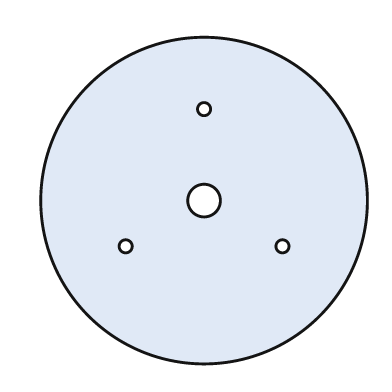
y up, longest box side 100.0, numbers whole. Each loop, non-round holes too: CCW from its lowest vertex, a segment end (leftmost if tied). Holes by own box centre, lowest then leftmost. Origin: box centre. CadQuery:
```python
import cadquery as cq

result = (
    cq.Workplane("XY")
    .moveTo(0.0, 0.0)
    .circle(50.0)
    .moveTo(-24.0, -14.0)
    .circle(2.0)
    .moveTo(24.0, -14.0)
    .circle(2.0)
    .moveTo(0.0, 0.0)
    .circle(5.0)
    .moveTo(0.0, 28.0)
    .circle(2.0)
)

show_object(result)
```